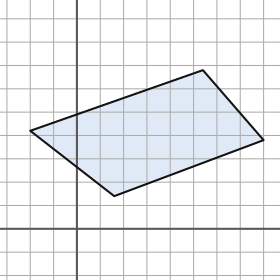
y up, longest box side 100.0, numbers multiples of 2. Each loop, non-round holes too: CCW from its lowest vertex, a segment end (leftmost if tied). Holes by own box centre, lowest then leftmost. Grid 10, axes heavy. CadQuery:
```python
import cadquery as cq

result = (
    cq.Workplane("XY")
    .moveTo(16.0, 14.0)
    .lineTo(80.0, 38.0)
    .lineTo(54.0, 68.0)
    .lineTo(-20.0, 42.0)
    .close()
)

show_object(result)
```